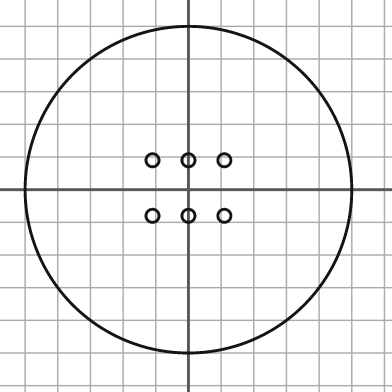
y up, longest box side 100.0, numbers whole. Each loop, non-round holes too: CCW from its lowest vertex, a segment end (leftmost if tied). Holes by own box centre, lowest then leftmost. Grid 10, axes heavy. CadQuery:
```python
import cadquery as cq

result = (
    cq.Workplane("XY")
    .moveTo(0.0, 0.0)
    .circle(50.0)
    .moveTo(-11.0, -8.0)
    .circle(2.0)
    .moveTo(0.0, -8.0)
    .circle(2.0)
    .moveTo(11.0, -8.0)
    .circle(2.0)
    .moveTo(-11.0, 9.0)
    .circle(2.0)
    .moveTo(0.0, 9.0)
    .circle(2.0)
    .moveTo(11.0, 9.0)
    .circle(2.0)
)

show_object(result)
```